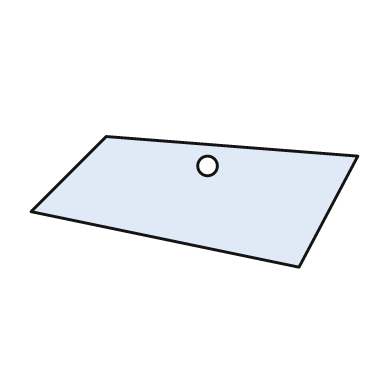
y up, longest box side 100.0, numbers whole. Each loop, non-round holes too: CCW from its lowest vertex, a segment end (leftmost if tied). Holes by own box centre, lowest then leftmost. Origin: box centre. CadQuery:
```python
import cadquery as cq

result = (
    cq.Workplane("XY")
    .moveTo(32.0, -20.0)
    .lineTo(50.0, 14.0)
    .lineTo(-27.0, 20.0)
    .lineTo(-50.0, -3.0)
    .close()
    .moveTo(4.0, 11.0)
    .circle(3.0)
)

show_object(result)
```